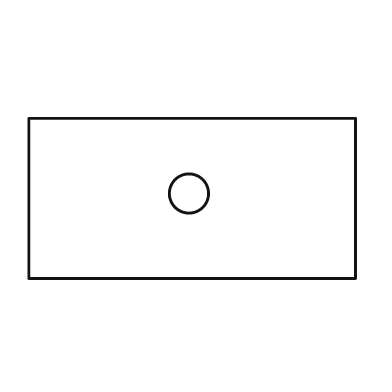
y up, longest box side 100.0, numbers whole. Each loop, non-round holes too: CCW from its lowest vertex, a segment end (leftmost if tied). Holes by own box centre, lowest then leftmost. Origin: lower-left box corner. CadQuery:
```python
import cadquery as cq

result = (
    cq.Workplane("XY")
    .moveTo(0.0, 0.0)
    .lineTo(100.0, 0.0)
    .lineTo(100.0, 49.0)
    .lineTo(0.0, 49.0)
    .close()
    .moveTo(49.0, 26.0)
    .circle(6.0)
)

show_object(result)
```